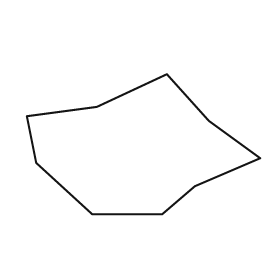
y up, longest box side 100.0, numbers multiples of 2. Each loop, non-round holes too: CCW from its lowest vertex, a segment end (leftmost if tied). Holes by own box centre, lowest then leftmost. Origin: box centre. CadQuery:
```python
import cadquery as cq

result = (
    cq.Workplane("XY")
    .moveTo(-22.0, -30.0)
    .lineTo(8.0, -30.0)
    .lineTo(22.0, -18.0)
    .lineTo(50.0, -6.0)
    .lineTo(28.0, 10.0)
    .lineTo(10.0, 30.0)
    .lineTo(-20.0, 16.0)
    .lineTo(-50.0, 12.0)
    .lineTo(-46.0, -8.0)
    .close()
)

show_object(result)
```